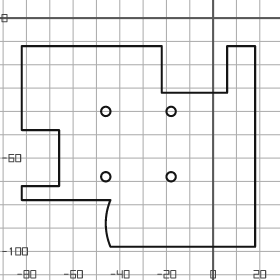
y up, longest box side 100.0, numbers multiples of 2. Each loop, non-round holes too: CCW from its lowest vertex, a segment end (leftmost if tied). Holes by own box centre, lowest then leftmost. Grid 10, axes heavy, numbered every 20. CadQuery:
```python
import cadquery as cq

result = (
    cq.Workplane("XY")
    .moveTo(-44.0, -98.0)
    .lineTo(18.0, -98.0)
    .lineTo(18.0, -12.0)
    .lineTo(6.0, -12.0)
    .lineTo(6.0, -32.0)
    .lineTo(-22.0, -32.0)
    .lineTo(-22.0, -12.0)
    .lineTo(-82.0, -12.0)
    .lineTo(-82.0, -48.0)
    .lineTo(-66.0, -48.0)
    .lineTo(-66.0, -72.0)
    .lineTo(-82.0, -72.0)
    .lineTo(-82.0, -78.0)
    .lineTo(-44.0, -78.0)
    .threePointArc((-46.0, -88.0), (-44.0, -98.0))
    .close()
    .moveTo(-46.0, -68.0)
    .circle(2.0)
    .moveTo(-18.0, -68.0)
    .circle(2.0)
    .moveTo(-46.0, -40.0)
    .circle(2.0)
    .moveTo(-18.0, -40.0)
    .circle(2.0)
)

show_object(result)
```